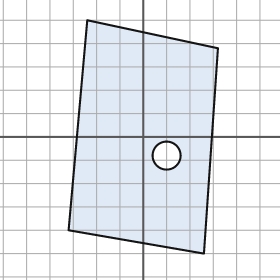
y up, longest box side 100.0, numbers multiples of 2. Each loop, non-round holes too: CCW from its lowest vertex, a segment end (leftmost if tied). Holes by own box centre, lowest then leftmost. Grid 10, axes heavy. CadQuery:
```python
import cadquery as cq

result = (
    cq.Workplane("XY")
    .moveTo(26.0, -50.0)
    .lineTo(32.0, 38.0)
    .lineTo(-24.0, 50.0)
    .lineTo(-32.0, -40.0)
    .close()
    .moveTo(10.0, -8.0)
    .circle(6.0)
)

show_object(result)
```